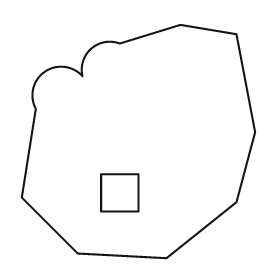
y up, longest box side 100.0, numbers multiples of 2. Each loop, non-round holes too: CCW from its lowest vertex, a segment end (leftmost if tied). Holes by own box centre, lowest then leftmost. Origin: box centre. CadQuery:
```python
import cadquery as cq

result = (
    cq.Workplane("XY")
    .moveTo(12.0, -50.0)
    .lineTo(42.0, -26.0)
    .lineTo(50.0, 4.0)
    .lineTo(42.0, 46.0)
    .lineTo(18.0, 50.0)
    .lineTo(-8.0, 42.0)
    .threePointArc((-20.0, 40.0), (-24.0, 28.0))
    .threePointArc((-40.0, 30.0), (-44.0, 14.0))
    .lineTo(-50.0, -24.0)
    .lineTo(-26.0, -48.0)
    .close()
    .moveTo(-16.0, -30.0)
    .lineTo(0.0, -30.0)
    .lineTo(0.0, -14.0)
    .lineTo(-16.0, -14.0)
    .close()
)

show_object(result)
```